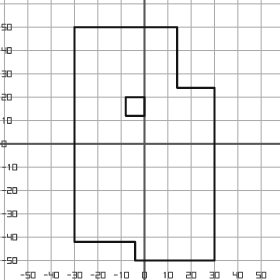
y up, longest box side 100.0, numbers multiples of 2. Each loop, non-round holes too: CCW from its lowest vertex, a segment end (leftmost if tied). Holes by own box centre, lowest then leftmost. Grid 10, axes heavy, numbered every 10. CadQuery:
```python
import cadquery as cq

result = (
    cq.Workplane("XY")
    .moveTo(-4.0, -50.0)
    .lineTo(30.0, -50.0)
    .lineTo(30.0, 24.0)
    .lineTo(14.0, 24.0)
    .lineTo(14.0, 50.0)
    .lineTo(-30.0, 50.0)
    .lineTo(-30.0, -42.0)
    .lineTo(-4.0, -42.0)
    .close()
    .moveTo(-8.0, 12.0)
    .lineTo(0.0, 12.0)
    .lineTo(0.0, 20.0)
    .lineTo(-8.0, 20.0)
    .close()
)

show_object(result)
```